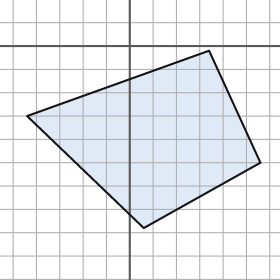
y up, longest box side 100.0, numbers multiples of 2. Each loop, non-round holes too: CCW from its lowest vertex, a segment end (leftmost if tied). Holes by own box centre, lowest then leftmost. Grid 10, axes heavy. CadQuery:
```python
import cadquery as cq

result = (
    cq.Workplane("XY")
    .moveTo(6.0, -78.0)
    .lineTo(56.0, -50.0)
    .lineTo(34.0, -2.0)
    .lineTo(-44.0, -30.0)
    .close()
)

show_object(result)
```